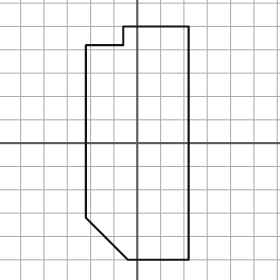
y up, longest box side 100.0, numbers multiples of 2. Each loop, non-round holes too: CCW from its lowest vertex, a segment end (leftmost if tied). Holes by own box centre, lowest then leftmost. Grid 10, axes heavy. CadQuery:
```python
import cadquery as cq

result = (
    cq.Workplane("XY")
    .moveTo(-4.0, -50.0)
    .lineTo(22.0, -50.0)
    .lineTo(22.0, 50.0)
    .lineTo(-6.0, 50.0)
    .lineTo(-6.0, 42.0)
    .lineTo(-22.0, 42.0)
    .lineTo(-22.0, -32.0)
    .close()
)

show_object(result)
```